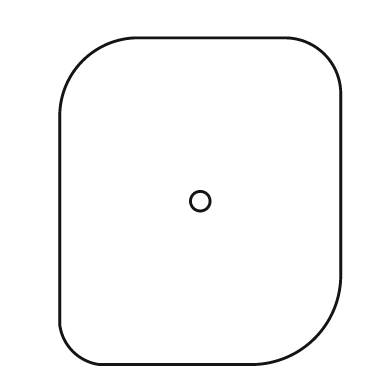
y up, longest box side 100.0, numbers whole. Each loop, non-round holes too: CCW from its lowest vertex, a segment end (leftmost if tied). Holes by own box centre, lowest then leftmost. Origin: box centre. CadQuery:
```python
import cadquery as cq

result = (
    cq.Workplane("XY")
    .moveTo(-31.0, -50.0)
    .lineTo(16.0, -50.0)
    .threePointArc((35.0, -42.0), (43.0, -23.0))
    .lineTo(43.0, 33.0)
    .threePointArc((38.0, 45.0), (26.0, 50.0))
    .lineTo(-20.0, 50.0)
    .threePointArc((-36.0, 43.0), (-43.0, 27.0))
    .lineTo(-43.0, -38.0)
    .threePointArc((-39.0, -46.0), (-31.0, -50.0))
    .close()
    .moveTo(0.0, 0.0)
    .circle(3.0)
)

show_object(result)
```